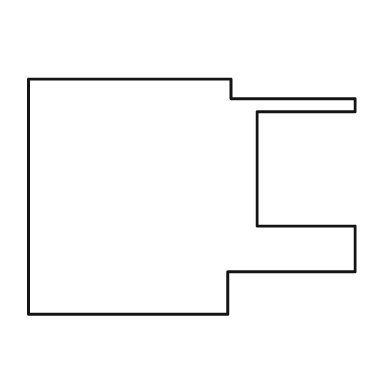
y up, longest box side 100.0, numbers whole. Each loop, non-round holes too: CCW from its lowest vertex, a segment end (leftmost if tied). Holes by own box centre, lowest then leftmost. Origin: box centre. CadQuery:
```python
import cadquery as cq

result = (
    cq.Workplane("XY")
    .moveTo(-50.0, -36.0)
    .lineTo(11.0, -36.0)
    .lineTo(11.0, -23.0)
    .lineTo(50.0, -23.0)
    .lineTo(50.0, -9.0)
    .lineTo(20.0, -9.0)
    .lineTo(20.0, 26.0)
    .lineTo(50.0, 26.0)
    .lineTo(50.0, 30.0)
    .lineTo(12.0, 30.0)
    .lineTo(12.0, 36.0)
    .lineTo(-50.0, 36.0)
    .close()
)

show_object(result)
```